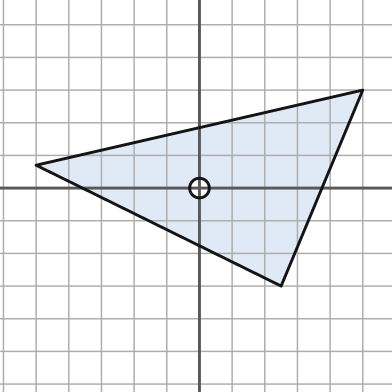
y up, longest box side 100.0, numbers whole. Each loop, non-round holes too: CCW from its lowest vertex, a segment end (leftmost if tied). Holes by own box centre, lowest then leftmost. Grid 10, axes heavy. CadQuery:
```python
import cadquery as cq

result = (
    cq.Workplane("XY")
    .moveTo(25.0, -30.0)
    .lineTo(50.0, 30.0)
    .lineTo(-50.0, 7.0)
    .close()
    .moveTo(0.0, 0.0)
    .circle(3.0)
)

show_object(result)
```